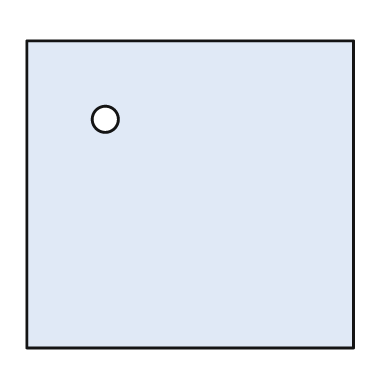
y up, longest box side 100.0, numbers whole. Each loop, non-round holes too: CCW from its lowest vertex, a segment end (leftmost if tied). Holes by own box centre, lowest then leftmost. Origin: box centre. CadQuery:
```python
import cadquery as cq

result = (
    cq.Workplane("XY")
    .moveTo(-50.0, -47.0)
    .lineTo(50.0, -47.0)
    .lineTo(50.0, 47.0)
    .lineTo(-50.0, 47.0)
    .close()
    .moveTo(-26.0, 23.0)
    .circle(4.0)
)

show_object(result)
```